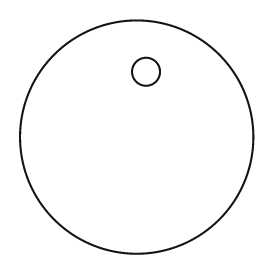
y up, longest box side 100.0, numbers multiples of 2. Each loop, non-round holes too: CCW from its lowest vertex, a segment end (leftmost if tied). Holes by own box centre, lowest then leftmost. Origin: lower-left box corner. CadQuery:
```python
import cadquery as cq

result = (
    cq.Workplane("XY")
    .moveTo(50.0, 50.0)
    .circle(50.0)
    .moveTo(54.0, 78.0)
    .circle(6.0)
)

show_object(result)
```